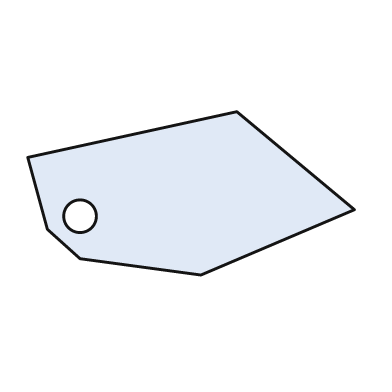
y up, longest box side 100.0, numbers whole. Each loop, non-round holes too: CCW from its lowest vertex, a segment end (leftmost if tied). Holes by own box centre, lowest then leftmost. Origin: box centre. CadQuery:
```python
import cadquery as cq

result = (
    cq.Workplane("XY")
    .moveTo(3.0, -25.0)
    .lineTo(50.0, -5.0)
    .lineTo(14.0, 25.0)
    .lineTo(-50.0, 11.0)
    .lineTo(-44.0, -11.0)
    .lineTo(-34.0, -20.0)
    .close()
    .moveTo(-34.0, -7.0)
    .circle(5.0)
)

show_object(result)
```